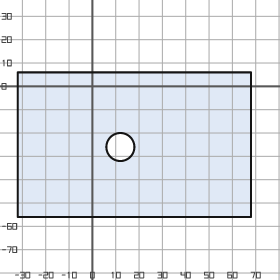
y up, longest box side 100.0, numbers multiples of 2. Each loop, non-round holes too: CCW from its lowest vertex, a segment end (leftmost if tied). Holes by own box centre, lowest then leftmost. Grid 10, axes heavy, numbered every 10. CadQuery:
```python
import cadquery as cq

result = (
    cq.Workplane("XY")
    .moveTo(-32.0, -56.0)
    .lineTo(68.0, -56.0)
    .lineTo(68.0, 6.0)
    .lineTo(-32.0, 6.0)
    .close()
    .moveTo(12.0, -26.0)
    .circle(6.0)
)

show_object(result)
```